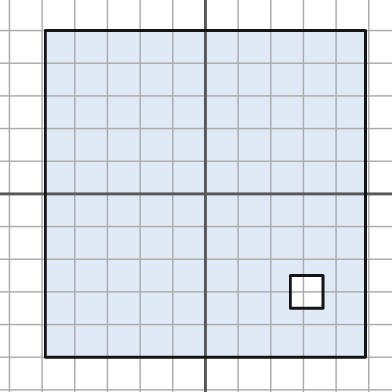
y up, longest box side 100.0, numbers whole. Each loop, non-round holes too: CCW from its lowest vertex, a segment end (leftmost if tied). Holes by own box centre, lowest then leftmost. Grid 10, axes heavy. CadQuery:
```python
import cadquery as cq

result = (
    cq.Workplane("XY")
    .moveTo(-49.0, -50.0)
    .lineTo(49.0, -50.0)
    .lineTo(49.0, 50.0)
    .lineTo(-49.0, 50.0)
    .close()
    .moveTo(26.0, -35.0)
    .lineTo(36.0, -35.0)
    .lineTo(36.0, -25.0)
    .lineTo(26.0, -25.0)
    .close()
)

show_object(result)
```